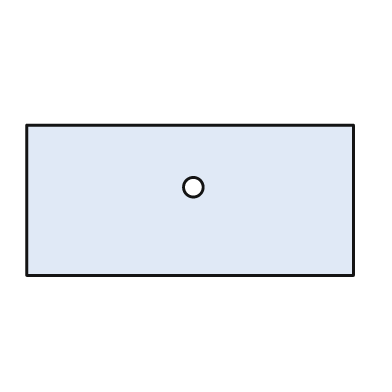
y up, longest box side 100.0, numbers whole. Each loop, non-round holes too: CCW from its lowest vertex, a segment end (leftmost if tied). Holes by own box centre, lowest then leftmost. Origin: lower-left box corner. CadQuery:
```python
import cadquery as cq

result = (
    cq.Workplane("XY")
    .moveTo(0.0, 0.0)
    .lineTo(100.0, 0.0)
    .lineTo(100.0, 46.0)
    .lineTo(0.0, 46.0)
    .close()
    .moveTo(51.0, 27.0)
    .circle(3.0)
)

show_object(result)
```